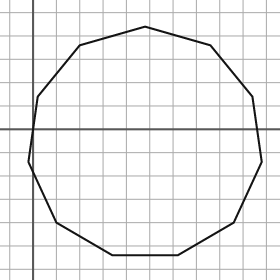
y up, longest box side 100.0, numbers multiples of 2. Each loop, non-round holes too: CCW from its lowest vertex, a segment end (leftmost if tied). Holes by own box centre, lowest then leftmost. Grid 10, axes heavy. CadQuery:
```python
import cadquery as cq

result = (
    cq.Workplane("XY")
    .moveTo(34.0, -54.0)
    .lineTo(62.0, -54.0)
    .lineTo(86.0, -40.0)
    .lineTo(98.0, -14.0)
    .lineTo(94.0, 14.0)
    .lineTo(76.0, 36.0)
    .lineTo(48.0, 44.0)
    .lineTo(20.0, 36.0)
    .lineTo(2.0, 14.0)
    .lineTo(-2.0, -14.0)
    .lineTo(10.0, -40.0)
    .close()
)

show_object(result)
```